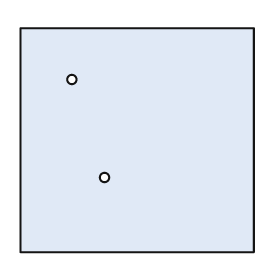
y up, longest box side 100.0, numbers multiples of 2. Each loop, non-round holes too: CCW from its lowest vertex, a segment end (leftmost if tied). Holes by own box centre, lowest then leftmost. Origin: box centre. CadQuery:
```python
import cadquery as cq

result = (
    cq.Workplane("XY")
    .moveTo(-50.0, -48.0)
    .lineTo(50.0, -48.0)
    .lineTo(50.0, 48.0)
    .lineTo(-50.0, 48.0)
    .close()
    .moveTo(-14.0, -16.0)
    .circle(2.0)
    .moveTo(-28.0, 26.0)
    .circle(2.0)
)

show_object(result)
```